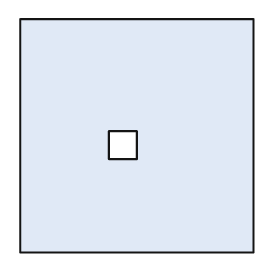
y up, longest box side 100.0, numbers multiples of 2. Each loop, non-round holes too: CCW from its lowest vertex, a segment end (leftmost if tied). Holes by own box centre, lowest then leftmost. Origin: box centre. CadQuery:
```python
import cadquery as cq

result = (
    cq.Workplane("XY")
    .moveTo(-50.0, -50.0)
    .lineTo(50.0, -50.0)
    .lineTo(50.0, 50.0)
    .lineTo(-50.0, 50.0)
    .close()
    .moveTo(-12.0, -10.0)
    .lineTo(0.0, -10.0)
    .lineTo(0.0, 2.0)
    .lineTo(-12.0, 2.0)
    .close()
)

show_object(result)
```